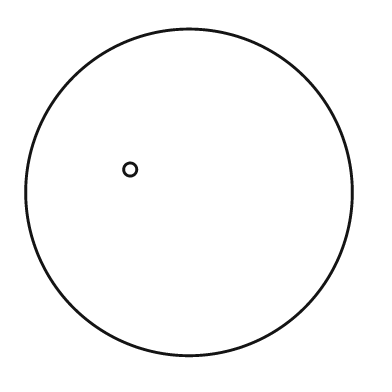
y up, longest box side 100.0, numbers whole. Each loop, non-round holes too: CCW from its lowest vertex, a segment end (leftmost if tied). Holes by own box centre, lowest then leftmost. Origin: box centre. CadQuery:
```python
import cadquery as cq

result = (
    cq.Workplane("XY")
    .moveTo(0.0, 0.0)
    .circle(50.0)
    .moveTo(-18.0, 7.0)
    .circle(2.0)
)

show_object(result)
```